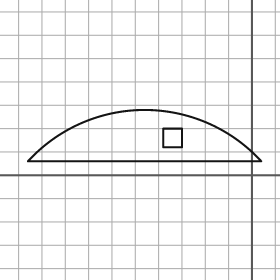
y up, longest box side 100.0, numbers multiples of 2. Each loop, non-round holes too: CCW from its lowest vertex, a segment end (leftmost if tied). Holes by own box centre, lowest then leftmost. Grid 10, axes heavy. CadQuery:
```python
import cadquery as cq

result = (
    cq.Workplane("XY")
    .moveTo(-96.0, 6.0)
    .lineTo(4.0, 6.0)
    .threePointArc((-46.0, 28.0), (-96.0, 6.0))
    .close()
    .moveTo(-38.0, 12.0)
    .lineTo(-30.0, 12.0)
    .lineTo(-30.0, 20.0)
    .lineTo(-38.0, 20.0)
    .close()
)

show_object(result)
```